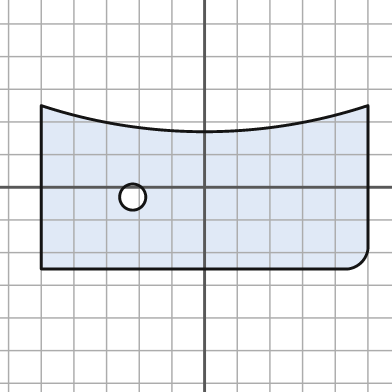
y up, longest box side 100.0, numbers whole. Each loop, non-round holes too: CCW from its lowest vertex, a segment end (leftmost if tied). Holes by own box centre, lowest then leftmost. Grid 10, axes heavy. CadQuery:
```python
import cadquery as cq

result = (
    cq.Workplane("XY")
    .moveTo(-50.0, -25.0)
    .lineTo(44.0, -25.0)
    .threePointArc((48.0, -23.0), (50.0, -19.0))
    .lineTo(50.0, 25.0)
    .threePointArc((0.0, 17.0), (-50.0, 25.0))
    .close()
    .moveTo(-22.0, -3.0)
    .circle(4.0)
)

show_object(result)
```